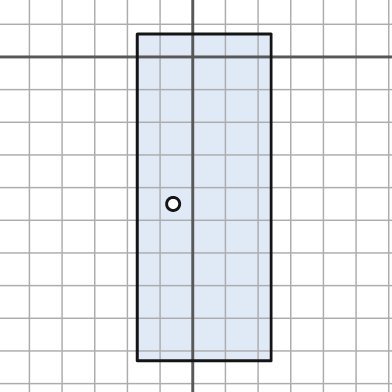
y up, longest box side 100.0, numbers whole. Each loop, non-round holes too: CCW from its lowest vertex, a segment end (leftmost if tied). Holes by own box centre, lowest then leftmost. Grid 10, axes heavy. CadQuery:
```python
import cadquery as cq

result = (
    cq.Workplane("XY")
    .moveTo(-17.0, -93.0)
    .lineTo(24.0, -93.0)
    .lineTo(24.0, 7.0)
    .lineTo(-17.0, 7.0)
    .close()
    .moveTo(-6.0, -45.0)
    .circle(2.0)
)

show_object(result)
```